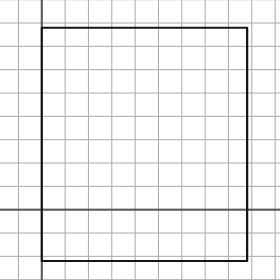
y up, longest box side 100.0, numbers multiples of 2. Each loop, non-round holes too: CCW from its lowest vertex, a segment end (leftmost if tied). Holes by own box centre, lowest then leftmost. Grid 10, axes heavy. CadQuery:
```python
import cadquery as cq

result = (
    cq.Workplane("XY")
    .moveTo(0.0, -22.0)
    .lineTo(88.0, -22.0)
    .lineTo(88.0, 78.0)
    .lineTo(0.0, 78.0)
    .close()
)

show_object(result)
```